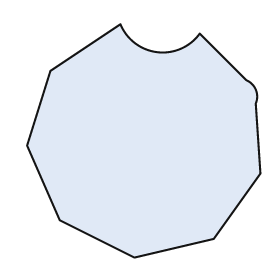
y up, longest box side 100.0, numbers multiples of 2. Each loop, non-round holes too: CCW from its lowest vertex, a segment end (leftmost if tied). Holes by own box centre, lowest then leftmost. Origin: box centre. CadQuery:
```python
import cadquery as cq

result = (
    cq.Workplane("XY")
    .moveTo(-4.0, -50.0)
    .lineTo(30.0, -42.0)
    .lineTo(50.0, -14.0)
    .lineTo(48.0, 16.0)
    .threePointArc((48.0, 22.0), (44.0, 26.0))
    .lineTo(24.0, 46.0)
    .threePointArc((6.0, 38.0), (-10.0, 50.0))
    .lineTo(-40.0, 30.0)
    .lineTo(-50.0, -2.0)
    .lineTo(-36.0, -34.0)
    .close()
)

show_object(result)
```